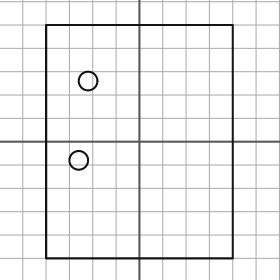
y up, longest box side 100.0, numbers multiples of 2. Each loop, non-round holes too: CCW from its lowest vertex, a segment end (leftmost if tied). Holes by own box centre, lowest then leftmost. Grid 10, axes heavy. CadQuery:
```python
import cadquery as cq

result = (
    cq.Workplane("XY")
    .moveTo(-40.0, -50.0)
    .lineTo(40.0, -50.0)
    .lineTo(40.0, 50.0)
    .lineTo(-40.0, 50.0)
    .close()
    .moveTo(-26.0, -8.0)
    .circle(4.0)
    .moveTo(-22.0, 26.0)
    .circle(4.0)
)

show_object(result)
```